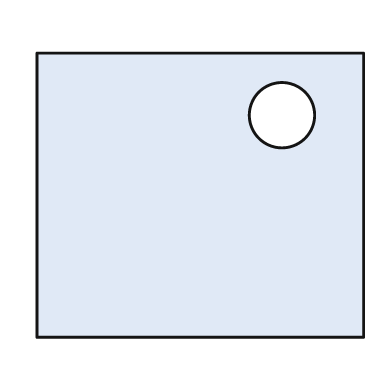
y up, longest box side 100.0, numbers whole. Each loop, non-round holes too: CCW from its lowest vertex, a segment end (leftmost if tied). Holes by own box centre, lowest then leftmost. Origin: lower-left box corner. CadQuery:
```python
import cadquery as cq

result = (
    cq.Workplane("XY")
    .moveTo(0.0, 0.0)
    .lineTo(100.0, 0.0)
    .lineTo(100.0, 87.0)
    .lineTo(0.0, 87.0)
    .close()
    .moveTo(75.0, 68.0)
    .circle(10.0)
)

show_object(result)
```